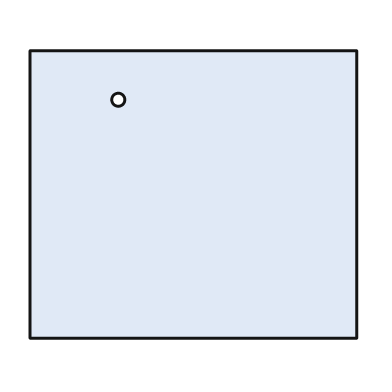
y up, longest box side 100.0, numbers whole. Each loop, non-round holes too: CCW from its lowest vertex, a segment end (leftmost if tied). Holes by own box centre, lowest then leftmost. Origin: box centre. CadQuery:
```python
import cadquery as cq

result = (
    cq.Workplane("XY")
    .moveTo(-50.0, -44.0)
    .lineTo(50.0, -44.0)
    .lineTo(50.0, 44.0)
    .lineTo(-50.0, 44.0)
    .close()
    .moveTo(-23.0, 29.0)
    .circle(2.0)
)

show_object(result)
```